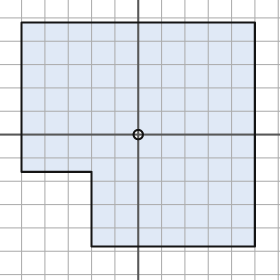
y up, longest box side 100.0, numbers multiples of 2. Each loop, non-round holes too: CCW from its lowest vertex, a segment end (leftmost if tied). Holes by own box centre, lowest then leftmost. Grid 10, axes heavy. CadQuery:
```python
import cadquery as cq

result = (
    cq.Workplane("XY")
    .moveTo(-20.0, -48.0)
    .lineTo(50.0, -48.0)
    .lineTo(50.0, 48.0)
    .lineTo(-50.0, 48.0)
    .lineTo(-50.0, -16.0)
    .lineTo(-20.0, -16.0)
    .close()
    .moveTo(0.0, 0.0)
    .circle(2.0)
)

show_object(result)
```